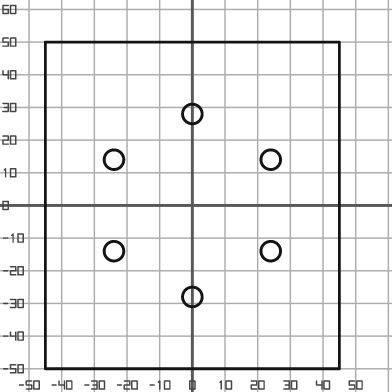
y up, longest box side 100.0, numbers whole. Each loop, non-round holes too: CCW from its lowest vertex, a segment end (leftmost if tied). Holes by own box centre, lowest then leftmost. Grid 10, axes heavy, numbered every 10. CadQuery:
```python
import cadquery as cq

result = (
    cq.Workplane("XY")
    .moveTo(-45.0, -50.0)
    .lineTo(45.0, -50.0)
    .lineTo(45.0, 50.0)
    .lineTo(-45.0, 50.0)
    .close()
    .moveTo(0.0, -28.0)
    .circle(3.0)
    .moveTo(-24.0, -14.0)
    .circle(3.0)
    .moveTo(24.0, -14.0)
    .circle(3.0)
    .moveTo(-24.0, 14.0)
    .circle(3.0)
    .moveTo(24.0, 14.0)
    .circle(3.0)
    .moveTo(0.0, 28.0)
    .circle(3.0)
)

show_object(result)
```